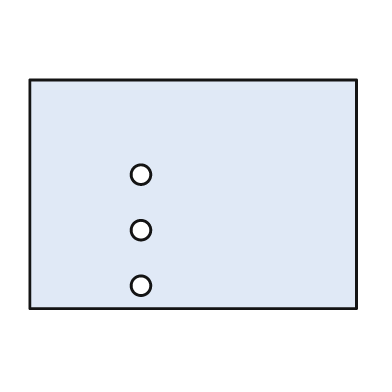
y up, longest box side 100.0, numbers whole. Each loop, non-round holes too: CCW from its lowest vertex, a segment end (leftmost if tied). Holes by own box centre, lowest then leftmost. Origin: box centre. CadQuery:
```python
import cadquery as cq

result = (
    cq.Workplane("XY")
    .moveTo(-50.0, -35.0)
    .lineTo(50.0, -35.0)
    .lineTo(50.0, 35.0)
    .lineTo(-50.0, 35.0)
    .close()
    .moveTo(-16.0, -28.0)
    .circle(3.0)
    .moveTo(-16.0, -11.0)
    .circle(3.0)
    .moveTo(-16.0, 6.0)
    .circle(3.0)
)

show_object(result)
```